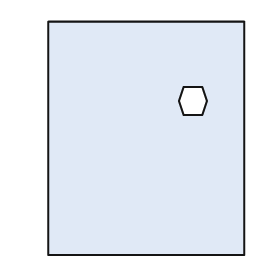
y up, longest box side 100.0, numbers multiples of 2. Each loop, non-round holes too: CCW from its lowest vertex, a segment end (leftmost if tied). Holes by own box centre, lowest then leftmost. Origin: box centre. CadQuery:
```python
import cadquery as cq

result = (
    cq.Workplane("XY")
    .moveTo(-42.0, -50.0)
    .lineTo(42.0, -50.0)
    .lineTo(42.0, 50.0)
    .lineTo(-42.0, 50.0)
    .close()
    .moveTo(16.0, 10.0)
    .lineTo(24.0, 10.0)
    .lineTo(26.0, 16.0)
    .lineTo(24.0, 22.0)
    .lineTo(16.0, 22.0)
    .lineTo(14.0, 16.0)
    .close()
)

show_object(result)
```